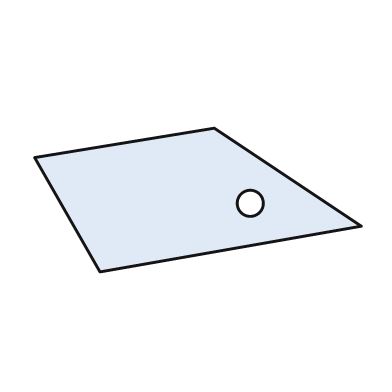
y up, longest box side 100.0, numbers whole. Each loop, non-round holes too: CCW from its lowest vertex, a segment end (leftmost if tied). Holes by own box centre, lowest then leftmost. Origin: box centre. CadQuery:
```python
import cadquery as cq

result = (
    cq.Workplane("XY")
    .moveTo(-30.0, -22.0)
    .lineTo(50.0, -8.0)
    .lineTo(5.0, 22.0)
    .lineTo(-50.0, 13.0)
    .close()
    .moveTo(16.0, -1.0)
    .circle(4.0)
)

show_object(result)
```